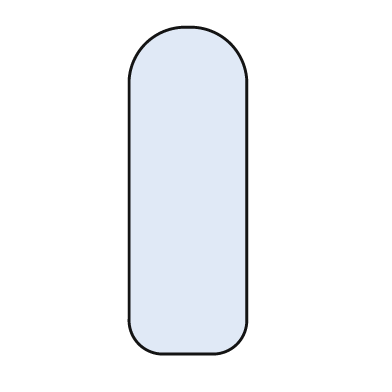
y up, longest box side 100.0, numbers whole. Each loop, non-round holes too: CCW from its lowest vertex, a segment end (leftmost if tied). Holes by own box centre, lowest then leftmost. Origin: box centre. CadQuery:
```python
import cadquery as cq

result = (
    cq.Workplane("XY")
    .moveTo(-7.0, -50.0)
    .lineTo(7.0, -50.0)
    .threePointArc((15.0, -47.0), (18.0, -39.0))
    .lineTo(18.0, 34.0)
    .threePointArc((13.0, 45.0), (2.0, 50.0))
    .lineTo(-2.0, 50.0)
    .threePointArc((-13.0, 45.0), (-18.0, 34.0))
    .lineTo(-18.0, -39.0)
    .threePointArc((-15.0, -47.0), (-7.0, -50.0))
    .close()
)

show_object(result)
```